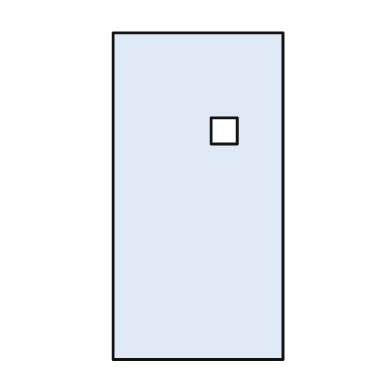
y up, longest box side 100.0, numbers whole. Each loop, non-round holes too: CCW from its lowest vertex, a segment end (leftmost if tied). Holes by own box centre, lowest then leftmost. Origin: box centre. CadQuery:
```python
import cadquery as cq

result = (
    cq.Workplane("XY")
    .moveTo(-26.0, -50.0)
    .lineTo(26.0, -50.0)
    .lineTo(26.0, 50.0)
    .lineTo(-26.0, 50.0)
    .close()
    .moveTo(4.0, 16.0)
    .lineTo(12.0, 16.0)
    .lineTo(12.0, 24.0)
    .lineTo(4.0, 24.0)
    .close()
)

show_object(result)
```